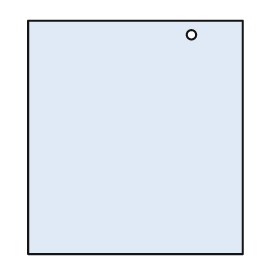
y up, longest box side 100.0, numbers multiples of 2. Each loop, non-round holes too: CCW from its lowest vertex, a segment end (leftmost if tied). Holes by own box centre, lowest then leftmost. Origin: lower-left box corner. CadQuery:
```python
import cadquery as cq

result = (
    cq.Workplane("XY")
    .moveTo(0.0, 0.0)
    .lineTo(92.0, 0.0)
    .lineTo(92.0, 100.0)
    .lineTo(0.0, 100.0)
    .close()
    .moveTo(70.0, 94.0)
    .circle(2.0)
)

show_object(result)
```